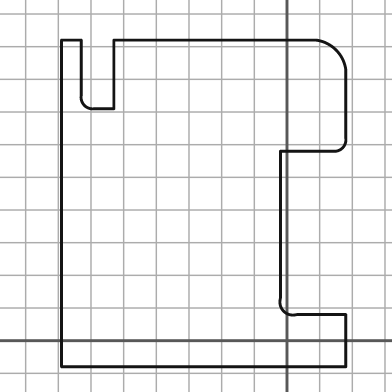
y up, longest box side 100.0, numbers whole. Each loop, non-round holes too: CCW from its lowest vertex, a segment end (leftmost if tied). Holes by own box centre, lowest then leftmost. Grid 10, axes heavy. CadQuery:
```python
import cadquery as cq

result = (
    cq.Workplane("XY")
    .moveTo(-69.0, -8.0)
    .lineTo(18.0, -8.0)
    .lineTo(18.0, 8.0)
    .lineTo(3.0, 8.0)
    .threePointArc((-1.0, 9.0), (-2.0, 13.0))
    .lineTo(-2.0, 58.0)
    .lineTo(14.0, 58.0)
    .threePointArc((17.0, 59.0), (18.0, 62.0))
    .lineTo(18.0, 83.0)
    .threePointArc((15.0, 89.0), (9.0, 92.0))
    .lineTo(-53.0, 92.0)
    .lineTo(-53.0, 71.0)
    .lineTo(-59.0, 71.0)
    .threePointArc((-62.0, 72.0), (-63.0, 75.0))
    .lineTo(-63.0, 92.0)
    .lineTo(-69.0, 92.0)
    .close()
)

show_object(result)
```